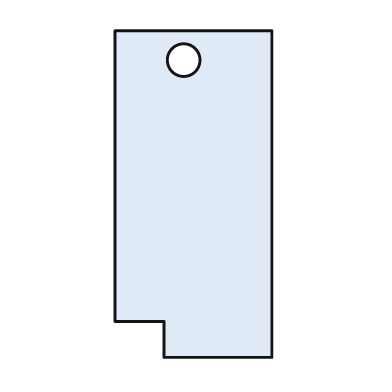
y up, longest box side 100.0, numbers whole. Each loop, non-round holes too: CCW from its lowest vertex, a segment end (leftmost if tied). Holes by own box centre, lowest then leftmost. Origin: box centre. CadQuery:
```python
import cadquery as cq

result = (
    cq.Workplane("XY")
    .moveTo(-9.0, -50.0)
    .lineTo(24.0, -50.0)
    .lineTo(24.0, 50.0)
    .lineTo(-24.0, 50.0)
    .lineTo(-24.0, -39.0)
    .lineTo(-9.0, -39.0)
    .close()
    .moveTo(-3.0, 41.0)
    .circle(5.0)
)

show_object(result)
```